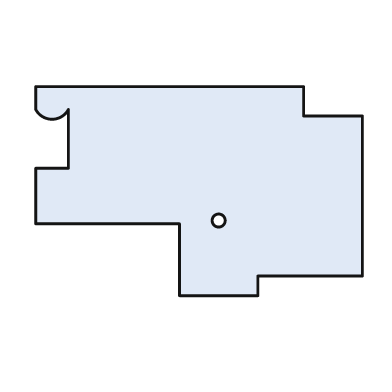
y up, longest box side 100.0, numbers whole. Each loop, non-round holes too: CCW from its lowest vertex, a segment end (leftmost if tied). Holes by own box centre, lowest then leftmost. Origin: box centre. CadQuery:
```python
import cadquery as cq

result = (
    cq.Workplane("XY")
    .moveTo(-6.0, -32.0)
    .lineTo(18.0, -32.0)
    .lineTo(18.0, -26.0)
    .lineTo(50.0, -26.0)
    .lineTo(50.0, 23.0)
    .lineTo(32.0, 23.0)
    .lineTo(32.0, 32.0)
    .lineTo(-50.0, 32.0)
    .lineTo(-50.0, 25.0)
    .threePointArc((-45.0, 22.0), (-40.0, 25.0))
    .lineTo(-40.0, 7.0)
    .lineTo(-50.0, 7.0)
    .lineTo(-50.0, -10.0)
    .lineTo(-6.0, -10.0)
    .close()
    .moveTo(6.0, -9.0)
    .circle(2.0)
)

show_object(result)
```